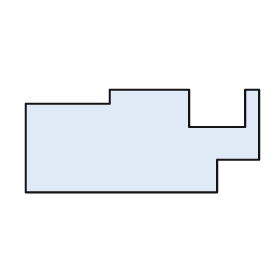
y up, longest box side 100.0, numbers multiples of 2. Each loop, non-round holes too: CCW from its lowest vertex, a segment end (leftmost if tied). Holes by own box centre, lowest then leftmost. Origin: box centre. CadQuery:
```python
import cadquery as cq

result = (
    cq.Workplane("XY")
    .moveTo(-50.0, -22.0)
    .lineTo(32.0, -22.0)
    .lineTo(32.0, -8.0)
    .lineTo(50.0, -8.0)
    .lineTo(50.0, 22.0)
    .lineTo(44.0, 22.0)
    .lineTo(44.0, 6.0)
    .lineTo(20.0, 6.0)
    .lineTo(20.0, 22.0)
    .lineTo(-14.0, 22.0)
    .lineTo(-14.0, 16.0)
    .lineTo(-50.0, 16.0)
    .close()
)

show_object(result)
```